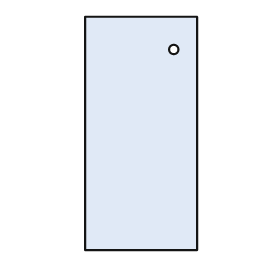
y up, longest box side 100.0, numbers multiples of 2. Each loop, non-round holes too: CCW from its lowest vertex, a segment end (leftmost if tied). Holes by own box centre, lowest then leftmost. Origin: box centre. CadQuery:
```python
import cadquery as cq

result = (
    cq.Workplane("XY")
    .moveTo(-24.0, -50.0)
    .lineTo(24.0, -50.0)
    .lineTo(24.0, 50.0)
    .lineTo(-24.0, 50.0)
    .close()
    .moveTo(14.0, 36.0)
    .circle(2.0)
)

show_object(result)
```